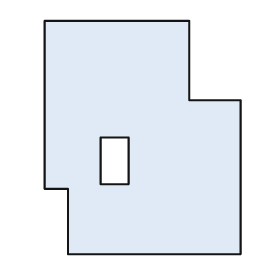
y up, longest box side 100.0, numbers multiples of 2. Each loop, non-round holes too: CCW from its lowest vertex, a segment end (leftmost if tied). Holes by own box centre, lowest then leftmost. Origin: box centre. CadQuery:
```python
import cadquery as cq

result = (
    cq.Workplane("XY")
    .moveTo(-32.0, -50.0)
    .lineTo(42.0, -50.0)
    .lineTo(42.0, 16.0)
    .lineTo(20.0, 16.0)
    .lineTo(20.0, 50.0)
    .lineTo(-42.0, 50.0)
    .lineTo(-42.0, -22.0)
    .lineTo(-32.0, -22.0)
    .close()
    .moveTo(-18.0, -20.0)
    .lineTo(-6.0, -20.0)
    .lineTo(-6.0, 0.0)
    .lineTo(-18.0, 0.0)
    .close()
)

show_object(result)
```